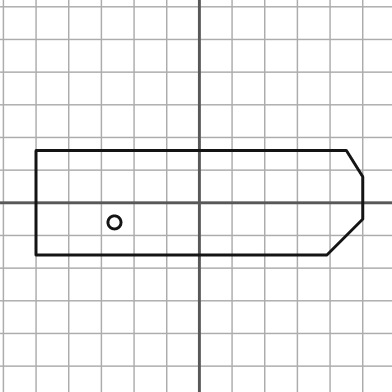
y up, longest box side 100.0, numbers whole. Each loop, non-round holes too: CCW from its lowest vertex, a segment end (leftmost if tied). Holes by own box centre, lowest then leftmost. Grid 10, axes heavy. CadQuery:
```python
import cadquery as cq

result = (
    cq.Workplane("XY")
    .moveTo(-50.0, -16.0)
    .lineTo(39.0, -16.0)
    .lineTo(50.0, -5.0)
    .lineTo(50.0, 8.0)
    .lineTo(45.0, 16.0)
    .lineTo(-50.0, 16.0)
    .close()
    .moveTo(-26.0, -6.0)
    .circle(2.0)
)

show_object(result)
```